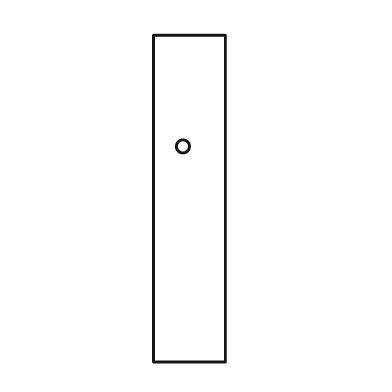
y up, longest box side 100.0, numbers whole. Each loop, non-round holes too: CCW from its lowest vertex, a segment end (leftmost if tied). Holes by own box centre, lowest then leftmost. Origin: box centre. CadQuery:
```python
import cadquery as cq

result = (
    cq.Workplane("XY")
    .moveTo(-11.0, -50.0)
    .lineTo(11.0, -50.0)
    .lineTo(11.0, 50.0)
    .lineTo(-11.0, 50.0)
    .close()
    .moveTo(-2.0, 16.0)
    .circle(2.0)
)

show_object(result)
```